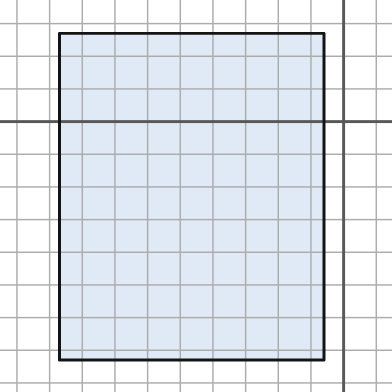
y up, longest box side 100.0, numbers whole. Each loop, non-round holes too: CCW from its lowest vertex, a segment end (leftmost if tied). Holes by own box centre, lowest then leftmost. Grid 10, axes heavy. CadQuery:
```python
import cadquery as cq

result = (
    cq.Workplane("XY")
    .moveTo(-87.0, -73.0)
    .lineTo(-6.0, -73.0)
    .lineTo(-6.0, 27.0)
    .lineTo(-87.0, 27.0)
    .close()
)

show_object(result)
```